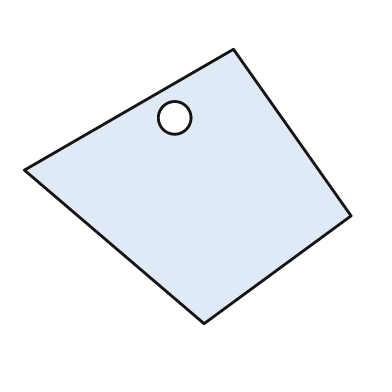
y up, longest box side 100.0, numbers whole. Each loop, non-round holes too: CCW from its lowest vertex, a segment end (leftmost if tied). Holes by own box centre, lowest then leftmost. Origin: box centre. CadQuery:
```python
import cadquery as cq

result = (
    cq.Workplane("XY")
    .moveTo(5.0, -42.0)
    .lineTo(50.0, -9.0)
    .lineTo(14.0, 42.0)
    .lineTo(-50.0, 5.0)
    .close()
    .moveTo(-4.0, 21.0)
    .circle(5.0)
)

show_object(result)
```